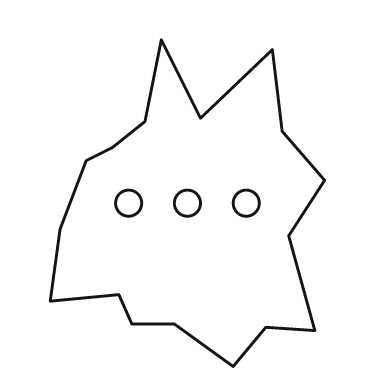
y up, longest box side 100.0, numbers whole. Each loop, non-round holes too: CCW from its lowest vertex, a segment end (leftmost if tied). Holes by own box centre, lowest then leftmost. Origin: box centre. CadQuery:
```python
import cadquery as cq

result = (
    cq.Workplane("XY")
    .moveTo(14.0, -50.0)
    .lineTo(24.0, -38.0)
    .lineTo(39.0, -39.0)
    .lineTo(31.0, -10.0)
    .lineTo(42.0, 7.0)
    .lineTo(29.0, 22.0)
    .lineTo(26.0, 47.0)
    .lineTo(4.0, 26.0)
    .lineTo(-8.0, 50.0)
    .lineTo(-13.0, 25.0)
    .lineTo(-23.0, 17.0)
    .lineTo(-31.0, 13.0)
    .lineTo(-39.0, -8.0)
    .lineTo(-42.0, -30.0)
    .lineTo(-21.0, -28.0)
    .lineTo(-17.0, -37.0)
    .lineTo(-4.0, -37.0)
    .close()
    .moveTo(-18.0, 0.0)
    .circle(4.0)
    .moveTo(0.0, 0.0)
    .circle(4.0)
    .moveTo(18.0, 0.0)
    .circle(4.0)
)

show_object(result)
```